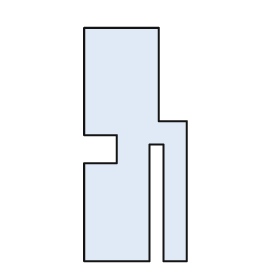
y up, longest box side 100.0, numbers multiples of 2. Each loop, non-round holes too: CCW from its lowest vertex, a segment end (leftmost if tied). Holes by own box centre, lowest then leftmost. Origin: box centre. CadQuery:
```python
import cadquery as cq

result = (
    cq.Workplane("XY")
    .moveTo(-22.0, -50.0)
    .lineTo(6.0, -50.0)
    .lineTo(6.0, 0.0)
    .lineTo(12.0, 0.0)
    .lineTo(12.0, -50.0)
    .lineTo(22.0, -50.0)
    .lineTo(22.0, 10.0)
    .lineTo(10.0, 10.0)
    .lineTo(10.0, 50.0)
    .lineTo(-22.0, 50.0)
    .lineTo(-22.0, 4.0)
    .lineTo(-8.0, 4.0)
    .lineTo(-8.0, -8.0)
    .lineTo(-22.0, -8.0)
    .close()
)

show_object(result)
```